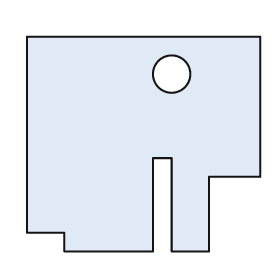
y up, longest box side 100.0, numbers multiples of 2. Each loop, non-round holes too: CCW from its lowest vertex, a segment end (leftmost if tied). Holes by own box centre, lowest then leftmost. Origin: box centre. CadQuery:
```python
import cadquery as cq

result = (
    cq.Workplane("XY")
    .moveTo(-34.0, -46.0)
    .lineTo(4.0, -46.0)
    .lineTo(4.0, -6.0)
    .lineTo(12.0, -6.0)
    .lineTo(12.0, -46.0)
    .lineTo(28.0, -46.0)
    .lineTo(28.0, -14.0)
    .lineTo(50.0, -14.0)
    .lineTo(50.0, 46.0)
    .lineTo(-50.0, 46.0)
    .lineTo(-50.0, -38.0)
    .lineTo(-34.0, -38.0)
    .close()
    .moveTo(12.0, 30.0)
    .circle(8.0)
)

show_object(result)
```